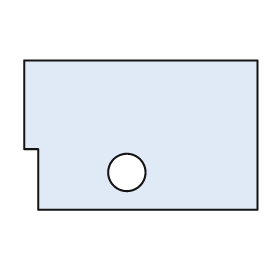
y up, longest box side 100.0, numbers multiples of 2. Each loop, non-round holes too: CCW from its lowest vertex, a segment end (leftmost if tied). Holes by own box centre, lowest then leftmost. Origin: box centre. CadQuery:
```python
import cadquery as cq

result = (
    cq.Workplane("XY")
    .moveTo(-44.0, -32.0)
    .lineTo(50.0, -32.0)
    .lineTo(50.0, 32.0)
    .lineTo(-50.0, 32.0)
    .lineTo(-50.0, -6.0)
    .lineTo(-44.0, -6.0)
    .close()
    .moveTo(-6.0, -16.0)
    .circle(8.0)
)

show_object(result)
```